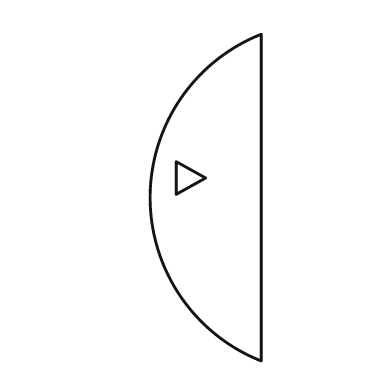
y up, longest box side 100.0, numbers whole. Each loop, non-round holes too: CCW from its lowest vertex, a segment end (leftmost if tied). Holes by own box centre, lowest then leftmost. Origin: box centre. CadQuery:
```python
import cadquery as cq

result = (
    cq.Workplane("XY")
    .moveTo(17.0, -50.0)
    .lineTo(17.0, 50.0)
    .threePointArc((-17.0, 0.0), (17.0, -50.0))
    .close()
    .moveTo(-9.0, 1.0)
    .lineTo(0.0, 6.0)
    .lineTo(-9.0, 11.0)
    .close()
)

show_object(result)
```